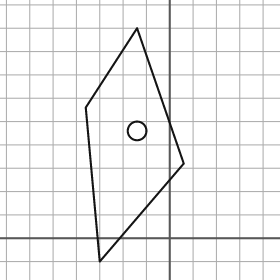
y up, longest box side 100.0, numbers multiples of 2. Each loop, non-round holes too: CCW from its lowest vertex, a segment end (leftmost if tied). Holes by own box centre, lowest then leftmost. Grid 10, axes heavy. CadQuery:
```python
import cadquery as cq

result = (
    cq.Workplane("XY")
    .moveTo(-30.0, -10.0)
    .lineTo(6.0, 32.0)
    .lineTo(-14.0, 90.0)
    .lineTo(-36.0, 56.0)
    .close()
    .moveTo(-14.0, 46.0)
    .circle(4.0)
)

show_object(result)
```